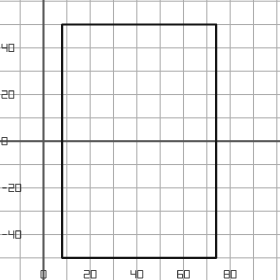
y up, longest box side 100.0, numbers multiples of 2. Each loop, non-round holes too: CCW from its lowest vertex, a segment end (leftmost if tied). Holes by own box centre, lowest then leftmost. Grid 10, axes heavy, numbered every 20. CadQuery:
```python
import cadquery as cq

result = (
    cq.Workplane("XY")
    .moveTo(8.0, -50.0)
    .lineTo(74.0, -50.0)
    .lineTo(74.0, 50.0)
    .lineTo(8.0, 50.0)
    .close()
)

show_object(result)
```